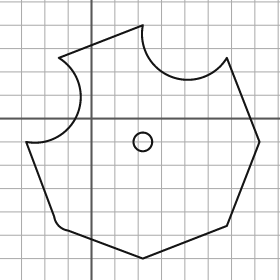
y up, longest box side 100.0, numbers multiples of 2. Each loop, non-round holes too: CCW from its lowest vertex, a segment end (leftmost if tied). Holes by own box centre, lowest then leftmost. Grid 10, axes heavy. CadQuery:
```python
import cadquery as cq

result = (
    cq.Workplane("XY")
    .moveTo(22.0, -60.0)
    .lineTo(58.0, -46.0)
    .lineTo(72.0, -10.0)
    .lineTo(58.0, 26.0)
    .threePointArc((34.0, 18.0), (22.0, 40.0))
    .lineTo(-14.0, 26.0)
    .threePointArc((-6.0, 2.0), (-28.0, -10.0))
    .lineTo(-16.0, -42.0)
    .threePointArc((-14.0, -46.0), (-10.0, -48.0))
    .close()
    .moveTo(22.0, -10.0)
    .circle(4.0)
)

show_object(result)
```